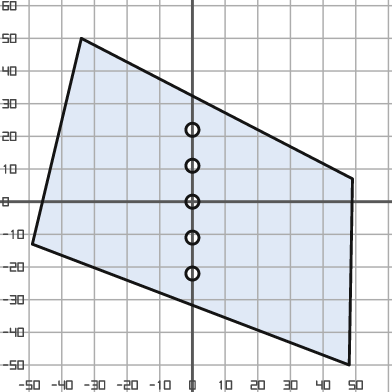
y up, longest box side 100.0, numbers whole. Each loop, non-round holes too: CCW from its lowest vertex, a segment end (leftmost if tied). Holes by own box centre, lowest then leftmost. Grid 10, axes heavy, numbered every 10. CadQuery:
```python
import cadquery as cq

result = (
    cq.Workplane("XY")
    .moveTo(48.0, -50.0)
    .lineTo(49.0, 7.0)
    .lineTo(-34.0, 50.0)
    .lineTo(-49.0, -13.0)
    .close()
    .moveTo(0.0, -22.0)
    .circle(2.0)
    .moveTo(0.0, -11.0)
    .circle(2.0)
    .moveTo(0.0, 0.0)
    .circle(2.0)
    .moveTo(0.0, 11.0)
    .circle(2.0)
    .moveTo(0.0, 22.0)
    .circle(2.0)
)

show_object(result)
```